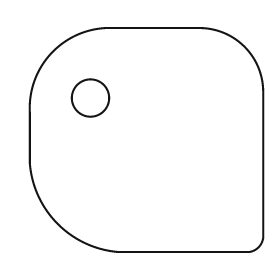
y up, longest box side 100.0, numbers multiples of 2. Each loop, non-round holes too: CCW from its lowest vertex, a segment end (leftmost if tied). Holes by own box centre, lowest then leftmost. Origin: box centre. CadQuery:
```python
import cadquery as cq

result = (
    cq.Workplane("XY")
    .moveTo(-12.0, -48.0)
    .lineTo(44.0, -48.0)
    .threePointArc((48.0, -46.0), (50.0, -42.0))
    .lineTo(50.0, 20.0)
    .threePointArc((42.0, 40.0), (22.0, 48.0))
    .lineTo(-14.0, 48.0)
    .threePointArc((-40.0, 38.0), (-50.0, 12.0))
    .lineTo(-50.0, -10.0)
    .threePointArc((-38.0, -36.0), (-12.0, -48.0))
    .close()
    .moveTo(-24.0, 18.0)
    .circle(8.0)
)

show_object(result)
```